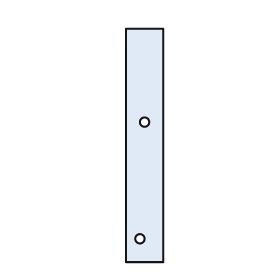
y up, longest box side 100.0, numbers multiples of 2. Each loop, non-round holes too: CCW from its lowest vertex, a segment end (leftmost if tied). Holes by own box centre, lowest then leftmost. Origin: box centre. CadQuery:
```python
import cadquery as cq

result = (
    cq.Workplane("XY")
    .moveTo(-8.0, -50.0)
    .lineTo(8.0, -50.0)
    .lineTo(8.0, 50.0)
    .lineTo(-8.0, 50.0)
    .close()
    .moveTo(-2.0, -40.0)
    .circle(2.0)
    .moveTo(0.0, 10.0)
    .circle(2.0)
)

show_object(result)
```